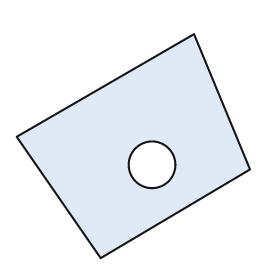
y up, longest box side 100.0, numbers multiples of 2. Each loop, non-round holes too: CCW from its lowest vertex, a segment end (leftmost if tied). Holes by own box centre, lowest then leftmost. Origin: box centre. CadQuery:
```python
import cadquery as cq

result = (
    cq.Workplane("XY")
    .moveTo(-14.0, -48.0)
    .lineTo(50.0, -10.0)
    .lineTo(26.0, 48.0)
    .lineTo(-50.0, 4.0)
    .close()
    .moveTo(8.0, -8.0)
    .circle(10.0)
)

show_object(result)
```